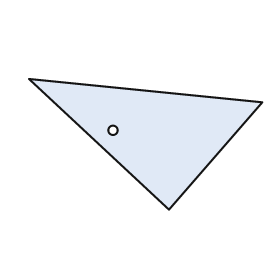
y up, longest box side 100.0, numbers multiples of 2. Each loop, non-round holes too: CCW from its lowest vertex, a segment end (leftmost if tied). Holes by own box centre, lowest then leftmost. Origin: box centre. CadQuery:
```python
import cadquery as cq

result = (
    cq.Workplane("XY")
    .moveTo(10.0, -28.0)
    .lineTo(50.0, 18.0)
    .lineTo(-50.0, 28.0)
    .close()
    .moveTo(-14.0, 6.0)
    .circle(2.0)
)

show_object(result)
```